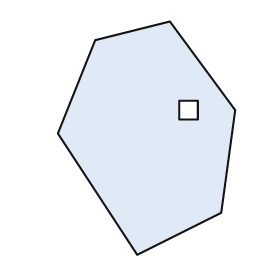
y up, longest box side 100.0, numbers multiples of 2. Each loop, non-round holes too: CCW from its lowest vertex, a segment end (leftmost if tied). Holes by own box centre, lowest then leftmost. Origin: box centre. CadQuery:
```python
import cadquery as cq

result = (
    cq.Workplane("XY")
    .moveTo(-4.0, -50.0)
    .lineTo(32.0, -32.0)
    .lineTo(38.0, 12.0)
    .lineTo(10.0, 50.0)
    .lineTo(-22.0, 42.0)
    .lineTo(-38.0, 2.0)
    .close()
    .moveTo(14.0, 8.0)
    .lineTo(22.0, 8.0)
    .lineTo(22.0, 16.0)
    .lineTo(14.0, 16.0)
    .close()
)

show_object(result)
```